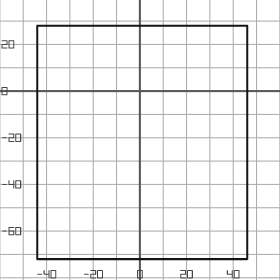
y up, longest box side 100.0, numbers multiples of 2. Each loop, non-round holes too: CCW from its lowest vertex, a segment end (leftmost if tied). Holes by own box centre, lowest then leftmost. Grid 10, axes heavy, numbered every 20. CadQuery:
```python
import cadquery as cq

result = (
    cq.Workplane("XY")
    .moveTo(-44.0, -72.0)
    .lineTo(46.0, -72.0)
    .lineTo(46.0, 28.0)
    .lineTo(-44.0, 28.0)
    .close()
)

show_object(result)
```